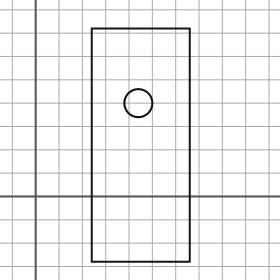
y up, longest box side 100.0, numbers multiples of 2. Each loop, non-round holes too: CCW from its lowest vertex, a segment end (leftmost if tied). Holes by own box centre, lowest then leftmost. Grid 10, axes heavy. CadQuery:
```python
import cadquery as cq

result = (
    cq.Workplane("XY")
    .moveTo(24.0, -28.0)
    .lineTo(66.0, -28.0)
    .lineTo(66.0, 72.0)
    .lineTo(24.0, 72.0)
    .close()
    .moveTo(44.0, 40.0)
    .circle(6.0)
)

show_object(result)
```